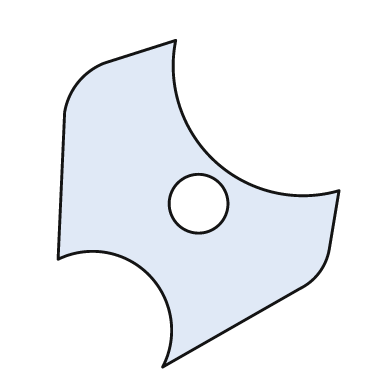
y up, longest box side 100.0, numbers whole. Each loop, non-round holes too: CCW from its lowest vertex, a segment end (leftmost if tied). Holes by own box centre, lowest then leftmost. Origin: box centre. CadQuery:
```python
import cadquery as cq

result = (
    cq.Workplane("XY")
    .moveTo(-11.0, -50.0)
    .lineTo(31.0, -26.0)
    .threePointArc((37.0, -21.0), (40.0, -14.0))
    .lineTo(43.0, 4.0)
    .threePointArc((5.0, 13.0), (-7.0, 50.0))
    .lineTo(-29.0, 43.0)
    .threePointArc((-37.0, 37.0), (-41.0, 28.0))
    .lineTo(-43.0, -17.0)
    .threePointArc((-15.0, -22.0), (-11.0, -50.0))
    .close()
    .moveTo(0.0, 0.0)
    .circle(9.0)
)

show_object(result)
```